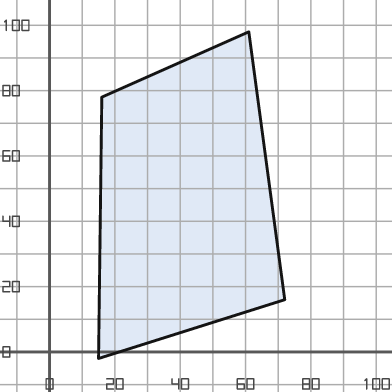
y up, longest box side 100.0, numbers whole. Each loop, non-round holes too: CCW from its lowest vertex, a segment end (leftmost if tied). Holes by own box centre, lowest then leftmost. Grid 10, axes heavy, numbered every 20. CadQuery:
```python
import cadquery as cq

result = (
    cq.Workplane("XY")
    .moveTo(15.0, -2.0)
    .lineTo(72.0, 16.0)
    .lineTo(61.0, 98.0)
    .lineTo(16.0, 78.0)
    .close()
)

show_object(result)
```